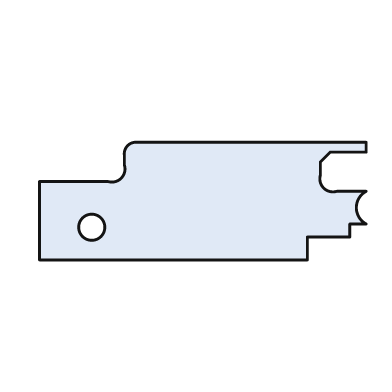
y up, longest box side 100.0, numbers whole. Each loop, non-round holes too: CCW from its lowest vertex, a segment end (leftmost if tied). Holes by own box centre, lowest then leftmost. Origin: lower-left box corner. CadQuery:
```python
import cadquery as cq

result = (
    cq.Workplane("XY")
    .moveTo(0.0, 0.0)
    .lineTo(82.0, 0.0)
    .lineTo(82.0, 7.0)
    .lineTo(95.0, 7.0)
    .lineTo(95.0, 11.0)
    .lineTo(100.0, 11.0)
    .threePointArc((97.0, 16.0), (100.0, 21.0))
    .lineTo(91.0, 21.0)
    .threePointArc((87.0, 22.0), (86.0, 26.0))
    .lineTo(86.0, 30.0)
    .lineTo(89.0, 33.0)
    .lineTo(100.0, 33.0)
    .lineTo(100.0, 36.0)
    .lineTo(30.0, 36.0)
    .threePointArc((27.0, 35.0), (26.0, 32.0))
    .lineTo(26.0, 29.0)
    .threePointArc((25.0, 25.0), (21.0, 24.0))
    .lineTo(0.0, 24.0)
    .close()
    .moveTo(16.0, 10.0)
    .circle(4.0)
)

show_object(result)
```